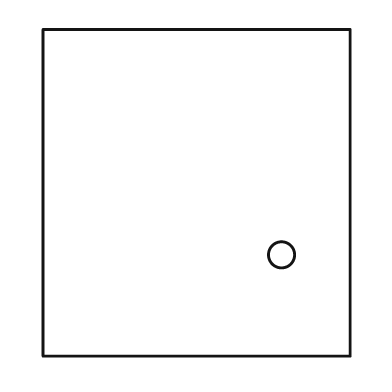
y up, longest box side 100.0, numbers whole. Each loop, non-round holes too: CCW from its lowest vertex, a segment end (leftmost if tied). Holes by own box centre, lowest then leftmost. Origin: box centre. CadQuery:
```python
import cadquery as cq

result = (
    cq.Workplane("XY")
    .moveTo(-47.0, -50.0)
    .lineTo(47.0, -50.0)
    .lineTo(47.0, 50.0)
    .lineTo(-47.0, 50.0)
    .close()
    .moveTo(26.0, -19.0)
    .circle(4.0)
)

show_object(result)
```